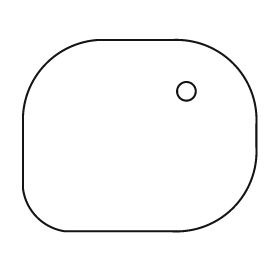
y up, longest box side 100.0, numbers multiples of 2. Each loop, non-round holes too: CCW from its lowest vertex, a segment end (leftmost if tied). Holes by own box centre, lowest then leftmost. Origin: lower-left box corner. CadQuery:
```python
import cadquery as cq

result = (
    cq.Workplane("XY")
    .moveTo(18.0, 0.0)
    .lineTo(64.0, 0.0)
    .threePointArc((90.0, 10.0), (100.0, 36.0))
    .lineTo(100.0, 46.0)
    .threePointArc((90.0, 72.0), (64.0, 82.0))
    .lineTo(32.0, 82.0)
    .threePointArc((10.0, 72.0), (0.0, 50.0))
    .lineTo(0.0, 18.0)
    .threePointArc((6.0, 6.0), (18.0, 0.0))
    .close()
    .moveTo(70.0, 60.0)
    .circle(4.0)
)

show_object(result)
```